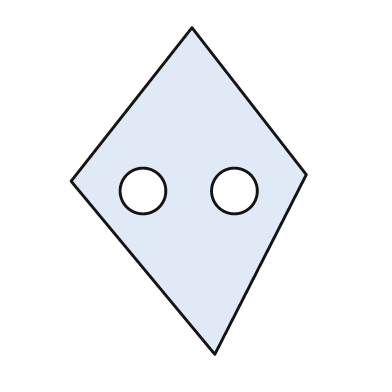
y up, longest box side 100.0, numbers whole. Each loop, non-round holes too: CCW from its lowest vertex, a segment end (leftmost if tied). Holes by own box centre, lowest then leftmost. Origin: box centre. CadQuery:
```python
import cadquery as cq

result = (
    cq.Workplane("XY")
    .moveTo(8.0, -50.0)
    .lineTo(36.0, 5.0)
    .lineTo(1.0, 50.0)
    .lineTo(-36.0, 3.0)
    .close()
    .moveTo(-14.0, 0.0)
    .circle(7.0)
    .moveTo(14.0, 0.0)
    .circle(7.0)
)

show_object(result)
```